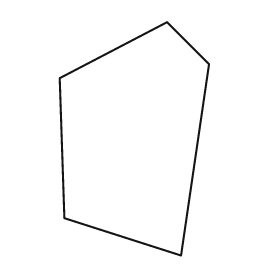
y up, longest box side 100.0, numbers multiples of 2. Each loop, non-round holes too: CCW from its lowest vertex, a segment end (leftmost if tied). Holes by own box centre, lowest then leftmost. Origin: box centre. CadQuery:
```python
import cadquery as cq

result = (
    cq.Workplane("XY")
    .moveTo(20.0, -50.0)
    .lineTo(32.0, 32.0)
    .lineTo(14.0, 50.0)
    .lineTo(-32.0, 26.0)
    .lineTo(-30.0, -34.0)
    .close()
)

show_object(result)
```